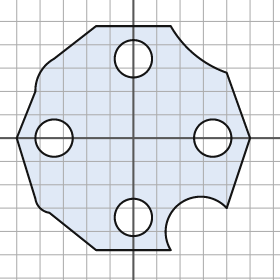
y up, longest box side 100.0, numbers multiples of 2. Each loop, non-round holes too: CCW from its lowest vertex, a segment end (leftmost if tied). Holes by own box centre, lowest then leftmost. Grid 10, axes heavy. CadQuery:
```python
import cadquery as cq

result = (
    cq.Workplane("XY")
    .moveTo(-16.0, -48.0)
    .lineTo(16.0, -48.0)
    .threePointArc((20.0, -28.0), (40.0, -30.0))
    .lineTo(50.0, 0.0)
    .lineTo(40.0, 28.0)
    .threePointArc((26.0, 36.0), (16.0, 48.0))
    .lineTo(-16.0, 48.0)
    .lineTo(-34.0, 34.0)
    .threePointArc((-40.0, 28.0), (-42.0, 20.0))
    .lineTo(-50.0, 0.0)
    .lineTo(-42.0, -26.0)
    .threePointArc((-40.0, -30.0), (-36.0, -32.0))
    .close()
    .moveTo(0.0, -34.0)
    .circle(8.0)
    .moveTo(-34.0, 0.0)
    .circle(8.0)
    .moveTo(34.0, 0.0)
    .circle(8.0)
    .moveTo(0.0, 34.0)
    .circle(8.0)
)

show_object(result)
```